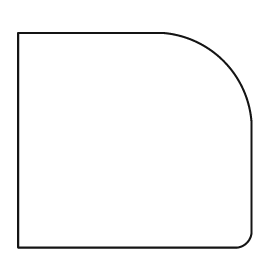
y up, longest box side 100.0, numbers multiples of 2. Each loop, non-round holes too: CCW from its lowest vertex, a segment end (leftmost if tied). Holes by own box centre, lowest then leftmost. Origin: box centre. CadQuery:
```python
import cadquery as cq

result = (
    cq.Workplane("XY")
    .moveTo(-50.0, -46.0)
    .lineTo(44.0, -46.0)
    .threePointArc((48.0, -44.0), (50.0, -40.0))
    .lineTo(50.0, 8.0)
    .threePointArc((38.0, 34.0), (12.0, 46.0))
    .lineTo(-50.0, 46.0)
    .close()
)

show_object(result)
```